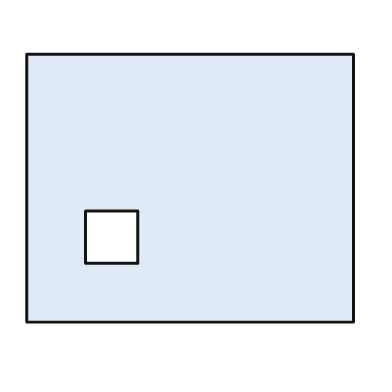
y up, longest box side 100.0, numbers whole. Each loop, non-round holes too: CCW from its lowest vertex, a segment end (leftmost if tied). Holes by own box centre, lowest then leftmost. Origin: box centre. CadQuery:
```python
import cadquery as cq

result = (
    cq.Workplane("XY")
    .moveTo(-50.0, -41.0)
    .lineTo(50.0, -41.0)
    .lineTo(50.0, 41.0)
    .lineTo(-50.0, 41.0)
    .close()
    .moveTo(-32.0, -23.0)
    .lineTo(-16.0, -23.0)
    .lineTo(-16.0, -7.0)
    .lineTo(-32.0, -7.0)
    .close()
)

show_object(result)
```